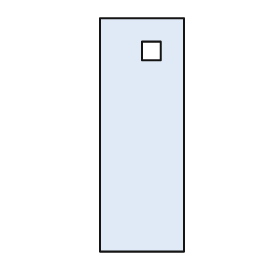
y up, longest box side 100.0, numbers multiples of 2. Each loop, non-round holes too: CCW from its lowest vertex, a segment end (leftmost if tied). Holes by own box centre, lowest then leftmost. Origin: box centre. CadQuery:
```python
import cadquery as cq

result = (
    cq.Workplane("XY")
    .moveTo(-18.0, -50.0)
    .lineTo(18.0, -50.0)
    .lineTo(18.0, 50.0)
    .lineTo(-18.0, 50.0)
    .close()
    .moveTo(0.0, 32.0)
    .lineTo(8.0, 32.0)
    .lineTo(8.0, 40.0)
    .lineTo(0.0, 40.0)
    .close()
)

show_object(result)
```